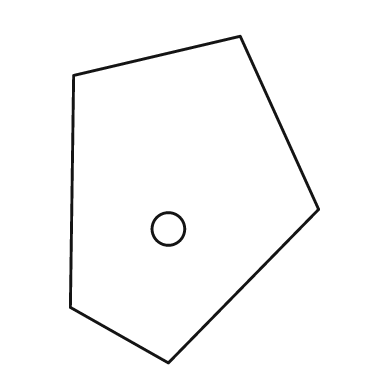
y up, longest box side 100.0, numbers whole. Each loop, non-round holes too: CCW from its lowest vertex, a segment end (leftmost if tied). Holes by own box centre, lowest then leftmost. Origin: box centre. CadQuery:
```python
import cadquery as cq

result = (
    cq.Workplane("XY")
    .moveTo(-8.0, -50.0)
    .lineTo(38.0, -3.0)
    .lineTo(14.0, 50.0)
    .lineTo(-37.0, 38.0)
    .lineTo(-38.0, -33.0)
    .close()
    .moveTo(-8.0, -9.0)
    .circle(5.0)
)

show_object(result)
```